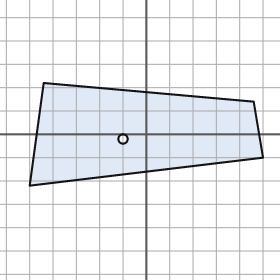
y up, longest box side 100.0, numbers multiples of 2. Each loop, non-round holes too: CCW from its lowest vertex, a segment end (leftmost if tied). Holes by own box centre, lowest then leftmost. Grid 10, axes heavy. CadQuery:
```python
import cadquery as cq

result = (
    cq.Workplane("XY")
    .moveTo(-50.0, -22.0)
    .lineTo(50.0, -10.0)
    .lineTo(46.0, 14.0)
    .lineTo(-44.0, 22.0)
    .close()
    .moveTo(-10.0, -2.0)
    .circle(2.0)
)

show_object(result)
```